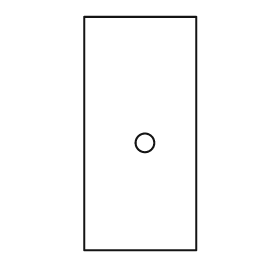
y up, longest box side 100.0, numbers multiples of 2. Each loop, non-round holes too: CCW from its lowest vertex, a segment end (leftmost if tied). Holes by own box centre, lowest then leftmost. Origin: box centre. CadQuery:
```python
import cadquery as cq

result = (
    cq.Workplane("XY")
    .moveTo(-24.0, -50.0)
    .lineTo(24.0, -50.0)
    .lineTo(24.0, 50.0)
    .lineTo(-24.0, 50.0)
    .close()
    .moveTo(2.0, -4.0)
    .circle(4.0)
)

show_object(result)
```